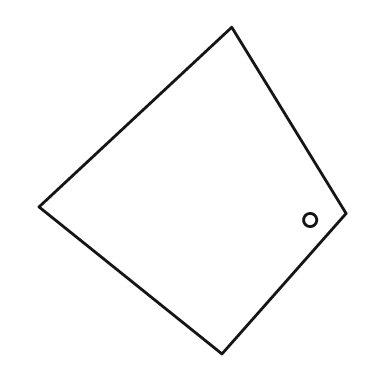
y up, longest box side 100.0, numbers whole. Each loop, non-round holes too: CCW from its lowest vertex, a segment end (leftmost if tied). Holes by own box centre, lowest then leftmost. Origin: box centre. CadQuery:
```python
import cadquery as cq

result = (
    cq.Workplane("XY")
    .moveTo(9.0, -50.0)
    .lineTo(47.0, -7.0)
    .lineTo(12.0, 50.0)
    .lineTo(-47.0, -5.0)
    .close()
    .moveTo(36.0, -9.0)
    .circle(2.0)
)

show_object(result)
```